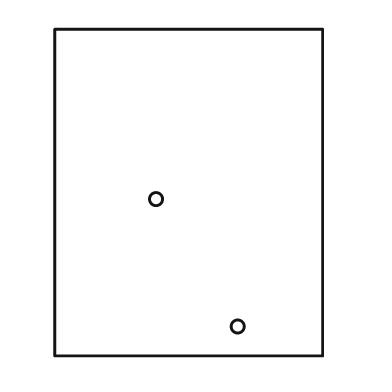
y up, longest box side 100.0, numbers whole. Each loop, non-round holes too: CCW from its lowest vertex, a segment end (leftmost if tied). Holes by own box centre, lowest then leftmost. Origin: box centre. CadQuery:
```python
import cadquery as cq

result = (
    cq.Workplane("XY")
    .moveTo(-41.0, -50.0)
    .lineTo(41.0, -50.0)
    .lineTo(41.0, 50.0)
    .lineTo(-41.0, 50.0)
    .close()
    .moveTo(15.0, -41.0)
    .circle(2.0)
    .moveTo(-10.0, -2.0)
    .circle(2.0)
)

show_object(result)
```